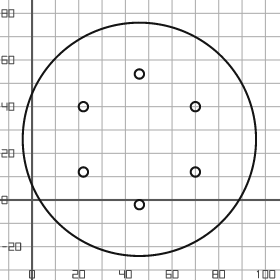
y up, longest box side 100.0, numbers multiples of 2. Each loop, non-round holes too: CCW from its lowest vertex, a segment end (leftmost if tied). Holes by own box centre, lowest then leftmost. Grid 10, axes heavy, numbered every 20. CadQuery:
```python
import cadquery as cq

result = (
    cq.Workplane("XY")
    .moveTo(46.0, 26.0)
    .circle(50.0)
    .moveTo(46.0, -2.0)
    .circle(2.0)
    .moveTo(22.0, 12.0)
    .circle(2.0)
    .moveTo(70.0, 12.0)
    .circle(2.0)
    .moveTo(22.0, 40.0)
    .circle(2.0)
    .moveTo(70.0, 40.0)
    .circle(2.0)
    .moveTo(46.0, 54.0)
    .circle(2.0)
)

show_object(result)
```